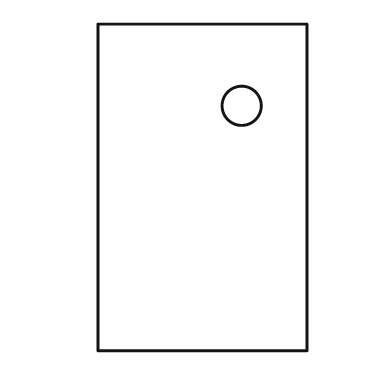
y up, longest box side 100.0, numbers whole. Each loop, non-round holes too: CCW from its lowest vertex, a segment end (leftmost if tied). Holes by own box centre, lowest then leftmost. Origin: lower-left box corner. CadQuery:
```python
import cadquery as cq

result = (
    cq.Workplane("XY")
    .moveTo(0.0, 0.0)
    .lineTo(64.0, 0.0)
    .lineTo(64.0, 100.0)
    .lineTo(0.0, 100.0)
    .close()
    .moveTo(44.0, 75.0)
    .circle(6.0)
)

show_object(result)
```